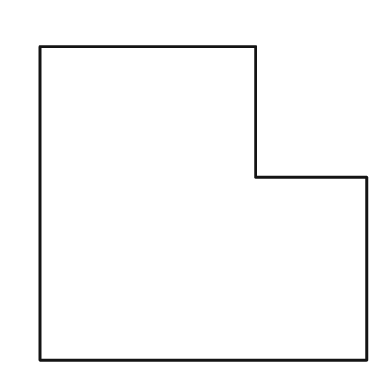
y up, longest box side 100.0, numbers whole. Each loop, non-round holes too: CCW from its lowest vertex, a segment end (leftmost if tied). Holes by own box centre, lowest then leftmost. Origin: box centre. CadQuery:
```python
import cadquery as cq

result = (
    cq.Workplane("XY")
    .moveTo(-50.0, -48.0)
    .lineTo(50.0, -48.0)
    .lineTo(50.0, 8.0)
    .lineTo(16.0, 8.0)
    .lineTo(16.0, 48.0)
    .lineTo(-50.0, 48.0)
    .close()
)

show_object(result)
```